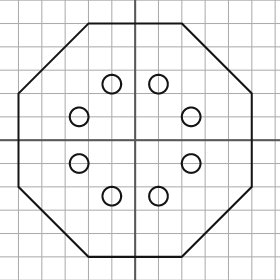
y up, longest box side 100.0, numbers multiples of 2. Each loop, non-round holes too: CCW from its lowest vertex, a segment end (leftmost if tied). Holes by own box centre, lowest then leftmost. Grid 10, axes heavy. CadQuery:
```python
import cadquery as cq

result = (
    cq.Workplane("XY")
    .moveTo(-20.0, -50.0)
    .lineTo(20.0, -50.0)
    .lineTo(50.0, -20.0)
    .lineTo(50.0, 20.0)
    .lineTo(20.0, 50.0)
    .lineTo(-20.0, 50.0)
    .lineTo(-50.0, 20.0)
    .lineTo(-50.0, -20.0)
    .close()
    .moveTo(-10.0, -24.0)
    .circle(4.0)
    .moveTo(10.0, -24.0)
    .circle(4.0)
    .moveTo(-24.0, -10.0)
    .circle(4.0)
    .moveTo(24.0, -10.0)
    .circle(4.0)
    .moveTo(-24.0, 10.0)
    .circle(4.0)
    .moveTo(24.0, 10.0)
    .circle(4.0)
    .moveTo(-10.0, 24.0)
    .circle(4.0)
    .moveTo(10.0, 24.0)
    .circle(4.0)
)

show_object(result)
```